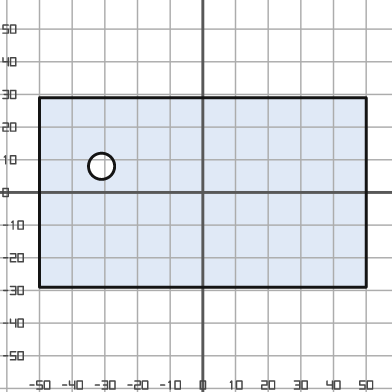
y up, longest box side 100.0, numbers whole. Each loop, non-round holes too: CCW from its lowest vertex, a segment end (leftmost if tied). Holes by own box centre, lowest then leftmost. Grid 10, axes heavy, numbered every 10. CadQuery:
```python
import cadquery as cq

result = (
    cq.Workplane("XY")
    .moveTo(-50.0, -29.0)
    .lineTo(50.0, -29.0)
    .lineTo(50.0, 29.0)
    .lineTo(-50.0, 29.0)
    .close()
    .moveTo(-31.0, 8.0)
    .circle(4.0)
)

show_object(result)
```